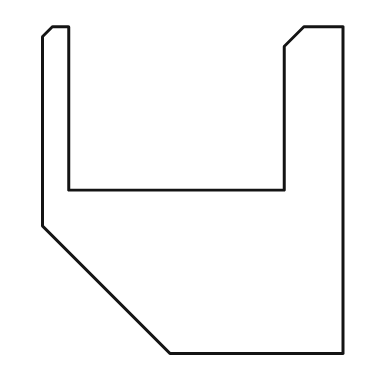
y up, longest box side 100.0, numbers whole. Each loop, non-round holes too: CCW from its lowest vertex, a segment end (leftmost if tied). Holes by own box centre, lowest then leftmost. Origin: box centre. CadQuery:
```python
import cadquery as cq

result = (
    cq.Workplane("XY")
    .moveTo(-7.0, -50.0)
    .lineTo(46.0, -50.0)
    .lineTo(46.0, 50.0)
    .lineTo(34.0, 50.0)
    .lineTo(28.0, 44.0)
    .lineTo(28.0, 0.0)
    .lineTo(-38.0, 0.0)
    .lineTo(-38.0, 50.0)
    .lineTo(-43.0, 50.0)
    .lineTo(-46.0, 47.0)
    .lineTo(-46.0, -11.0)
    .close()
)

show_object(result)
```